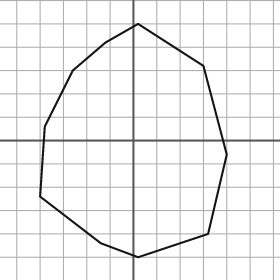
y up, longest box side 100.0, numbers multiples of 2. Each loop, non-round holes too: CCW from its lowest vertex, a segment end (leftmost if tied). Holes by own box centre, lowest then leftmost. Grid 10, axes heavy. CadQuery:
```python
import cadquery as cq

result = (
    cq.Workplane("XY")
    .moveTo(2.0, -50.0)
    .lineTo(32.0, -40.0)
    .lineTo(40.0, -6.0)
    .lineTo(30.0, 32.0)
    .lineTo(2.0, 50.0)
    .lineTo(-12.0, 42.0)
    .lineTo(-26.0, 30.0)
    .lineTo(-38.0, 6.0)
    .lineTo(-40.0, -24.0)
    .lineTo(-14.0, -44.0)
    .close()
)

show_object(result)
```